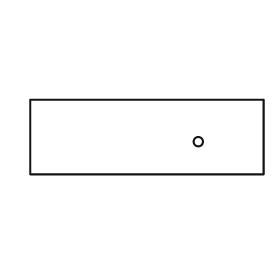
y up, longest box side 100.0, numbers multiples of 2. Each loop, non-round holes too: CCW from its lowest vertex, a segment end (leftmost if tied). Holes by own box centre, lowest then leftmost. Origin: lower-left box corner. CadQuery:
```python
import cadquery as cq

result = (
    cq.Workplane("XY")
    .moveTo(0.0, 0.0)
    .lineTo(100.0, 0.0)
    .lineTo(100.0, 32.0)
    .lineTo(0.0, 32.0)
    .close()
    .moveTo(72.0, 14.0)
    .circle(2.0)
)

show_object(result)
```